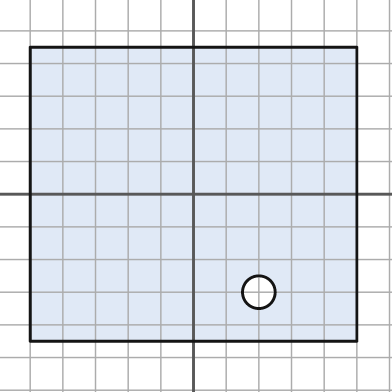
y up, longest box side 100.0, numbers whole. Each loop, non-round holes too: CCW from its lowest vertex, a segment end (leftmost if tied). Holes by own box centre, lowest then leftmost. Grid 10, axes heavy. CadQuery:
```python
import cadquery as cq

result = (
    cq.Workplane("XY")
    .moveTo(-50.0, -45.0)
    .lineTo(50.0, -45.0)
    .lineTo(50.0, 45.0)
    .lineTo(-50.0, 45.0)
    .close()
    .moveTo(20.0, -30.0)
    .circle(5.0)
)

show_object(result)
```